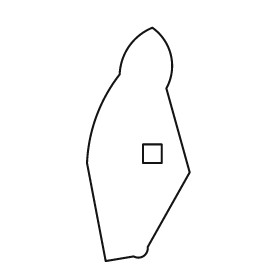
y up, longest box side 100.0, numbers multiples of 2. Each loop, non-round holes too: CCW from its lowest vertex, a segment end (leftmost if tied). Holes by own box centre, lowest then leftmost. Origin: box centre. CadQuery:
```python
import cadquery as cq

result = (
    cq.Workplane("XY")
    .moveTo(-14.0, -50.0)
    .lineTo(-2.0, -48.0)
    .threePointArc((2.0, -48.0), (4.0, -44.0))
    .lineTo(22.0, -12.0)
    .lineTo(12.0, 24.0)
    .threePointArc((14.0, 38.0), (6.0, 50.0))
    .threePointArc((-4.0, 42.0), (-8.0, 30.0))
    .threePointArc((-18.0, 12.0), (-22.0, -8.0))
    .close()
    .moveTo(2.0, -8.0)
    .lineTo(10.0, -8.0)
    .lineTo(10.0, 0.0)
    .lineTo(2.0, 0.0)
    .close()
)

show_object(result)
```